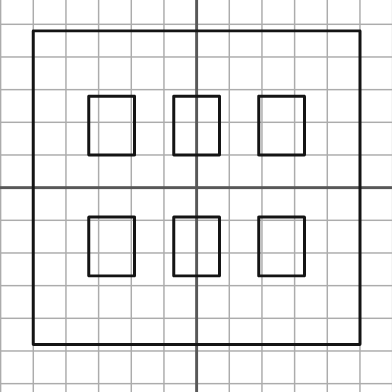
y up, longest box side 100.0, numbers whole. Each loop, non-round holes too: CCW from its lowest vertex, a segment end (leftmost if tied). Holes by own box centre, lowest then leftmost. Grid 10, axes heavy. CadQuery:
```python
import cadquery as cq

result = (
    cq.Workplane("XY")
    .moveTo(-50.0, -48.0)
    .lineTo(50.0, -48.0)
    .lineTo(50.0, 48.0)
    .lineTo(-50.0, 48.0)
    .close()
    .moveTo(-33.0, -27.0)
    .lineTo(-19.0, -27.0)
    .lineTo(-19.0, -9.0)
    .lineTo(-33.0, -9.0)
    .close()
    .moveTo(-7.0, -27.0)
    .lineTo(7.0, -27.0)
    .lineTo(7.0, -9.0)
    .lineTo(-7.0, -9.0)
    .close()
    .moveTo(19.0, -27.0)
    .lineTo(33.0, -27.0)
    .lineTo(33.0, -9.0)
    .lineTo(19.0, -9.0)
    .close()
    .moveTo(-33.0, 10.0)
    .lineTo(-19.0, 10.0)
    .lineTo(-19.0, 28.0)
    .lineTo(-33.0, 28.0)
    .close()
    .moveTo(-7.0, 10.0)
    .lineTo(7.0, 10.0)
    .lineTo(7.0, 28.0)
    .lineTo(-7.0, 28.0)
    .close()
    .moveTo(19.0, 10.0)
    .lineTo(33.0, 10.0)
    .lineTo(33.0, 28.0)
    .lineTo(19.0, 28.0)
    .close()
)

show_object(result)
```